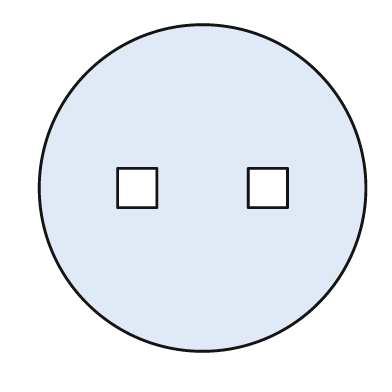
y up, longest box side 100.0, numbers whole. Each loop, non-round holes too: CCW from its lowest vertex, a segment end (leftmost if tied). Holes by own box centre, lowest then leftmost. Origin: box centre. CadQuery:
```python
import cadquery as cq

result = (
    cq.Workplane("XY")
    .moveTo(0.0, 0.0)
    .circle(50.0)
    .moveTo(-26.0, -6.0)
    .lineTo(-14.0, -6.0)
    .lineTo(-14.0, 6.0)
    .lineTo(-26.0, 6.0)
    .close()
    .moveTo(14.0, -6.0)
    .lineTo(26.0, -6.0)
    .lineTo(26.0, 6.0)
    .lineTo(14.0, 6.0)
    .close()
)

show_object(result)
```